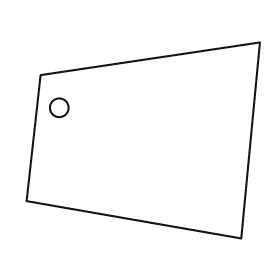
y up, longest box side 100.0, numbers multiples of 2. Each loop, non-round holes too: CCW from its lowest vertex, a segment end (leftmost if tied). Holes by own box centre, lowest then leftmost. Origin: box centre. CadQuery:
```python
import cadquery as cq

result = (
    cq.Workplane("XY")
    .moveTo(42.0, -42.0)
    .lineTo(50.0, 42.0)
    .lineTo(-44.0, 28.0)
    .lineTo(-50.0, -26.0)
    .close()
    .moveTo(-36.0, 14.0)
    .circle(4.0)
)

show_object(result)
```